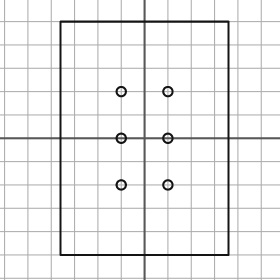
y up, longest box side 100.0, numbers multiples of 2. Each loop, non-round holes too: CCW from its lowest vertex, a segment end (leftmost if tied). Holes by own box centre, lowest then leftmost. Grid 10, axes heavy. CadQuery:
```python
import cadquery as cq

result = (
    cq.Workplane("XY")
    .moveTo(-36.0, -50.0)
    .lineTo(36.0, -50.0)
    .lineTo(36.0, 50.0)
    .lineTo(-36.0, 50.0)
    .close()
    .moveTo(-10.0, -20.0)
    .circle(2.0)
    .moveTo(10.0, -20.0)
    .circle(2.0)
    .moveTo(-10.0, 0.0)
    .circle(2.0)
    .moveTo(10.0, 0.0)
    .circle(2.0)
    .moveTo(-10.0, 20.0)
    .circle(2.0)
    .moveTo(10.0, 20.0)
    .circle(2.0)
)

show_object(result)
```